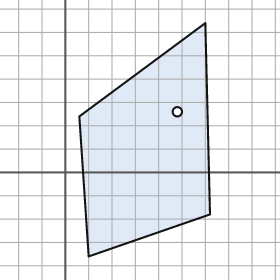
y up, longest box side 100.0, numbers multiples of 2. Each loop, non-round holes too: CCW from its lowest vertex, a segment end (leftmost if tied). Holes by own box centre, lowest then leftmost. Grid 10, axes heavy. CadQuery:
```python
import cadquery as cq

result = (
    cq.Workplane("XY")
    .moveTo(10.0, -36.0)
    .lineTo(62.0, -18.0)
    .lineTo(60.0, 64.0)
    .lineTo(6.0, 24.0)
    .close()
    .moveTo(48.0, 26.0)
    .circle(2.0)
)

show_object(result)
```